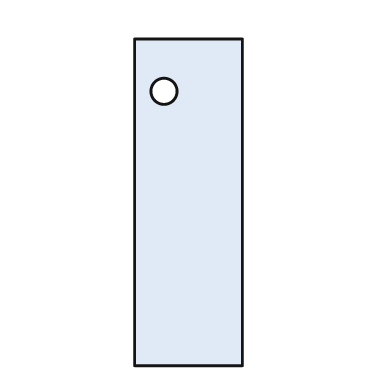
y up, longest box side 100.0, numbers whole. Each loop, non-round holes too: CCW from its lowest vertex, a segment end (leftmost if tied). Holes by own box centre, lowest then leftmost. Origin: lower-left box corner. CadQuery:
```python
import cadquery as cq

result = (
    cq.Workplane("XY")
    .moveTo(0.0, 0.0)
    .lineTo(33.0, 0.0)
    .lineTo(33.0, 100.0)
    .lineTo(0.0, 100.0)
    .close()
    .moveTo(9.0, 84.0)
    .circle(4.0)
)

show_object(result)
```